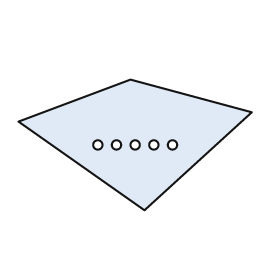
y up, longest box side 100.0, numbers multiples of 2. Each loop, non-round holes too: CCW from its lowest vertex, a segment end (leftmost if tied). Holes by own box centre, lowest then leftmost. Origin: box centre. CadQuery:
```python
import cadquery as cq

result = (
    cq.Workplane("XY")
    .moveTo(4.0, -28.0)
    .lineTo(50.0, 14.0)
    .lineTo(-2.0, 28.0)
    .lineTo(-50.0, 10.0)
    .close()
    .moveTo(-16.0, 0.0)
    .circle(2.0)
    .moveTo(-8.0, 0.0)
    .circle(2.0)
    .moveTo(0.0, 0.0)
    .circle(2.0)
    .moveTo(8.0, 0.0)
    .circle(2.0)
    .moveTo(16.0, 0.0)
    .circle(2.0)
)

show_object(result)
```